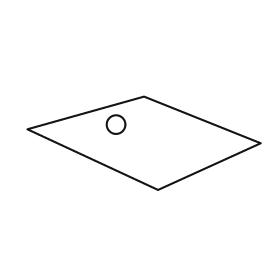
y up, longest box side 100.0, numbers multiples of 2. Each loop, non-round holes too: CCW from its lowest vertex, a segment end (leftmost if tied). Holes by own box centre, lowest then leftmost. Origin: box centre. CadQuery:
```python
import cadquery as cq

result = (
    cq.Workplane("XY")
    .moveTo(6.0, -20.0)
    .lineTo(50.0, 0.0)
    .lineTo(0.0, 20.0)
    .lineTo(-50.0, 6.0)
    .close()
    .moveTo(-12.0, 8.0)
    .circle(4.0)
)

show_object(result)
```